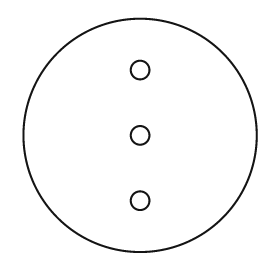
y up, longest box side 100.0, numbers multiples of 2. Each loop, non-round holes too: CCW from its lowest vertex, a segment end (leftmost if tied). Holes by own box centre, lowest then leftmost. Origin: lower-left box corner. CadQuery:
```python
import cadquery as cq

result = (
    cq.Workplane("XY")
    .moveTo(50.0, 50.0)
    .circle(50.0)
    .moveTo(50.0, 22.0)
    .circle(4.0)
    .moveTo(50.0, 50.0)
    .circle(4.0)
    .moveTo(50.0, 78.0)
    .circle(4.0)
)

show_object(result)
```